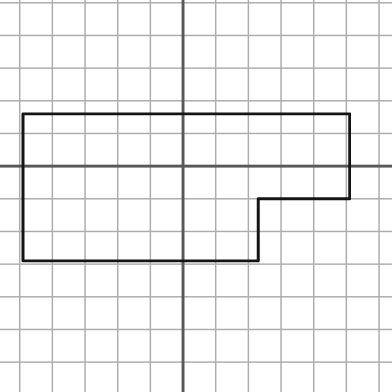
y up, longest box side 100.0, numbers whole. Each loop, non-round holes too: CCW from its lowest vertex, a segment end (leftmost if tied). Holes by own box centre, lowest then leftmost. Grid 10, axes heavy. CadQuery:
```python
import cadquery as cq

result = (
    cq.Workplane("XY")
    .moveTo(-49.0, -29.0)
    .lineTo(23.0, -29.0)
    .lineTo(23.0, -10.0)
    .lineTo(51.0, -10.0)
    .lineTo(51.0, 16.0)
    .lineTo(-49.0, 16.0)
    .close()
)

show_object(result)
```